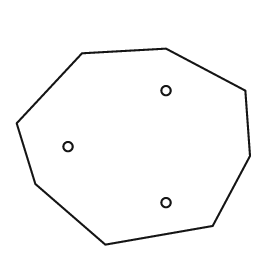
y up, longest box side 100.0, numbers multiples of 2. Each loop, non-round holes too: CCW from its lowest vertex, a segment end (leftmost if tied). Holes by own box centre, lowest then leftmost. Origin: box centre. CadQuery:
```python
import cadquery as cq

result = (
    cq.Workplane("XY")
    .moveTo(-12.0, -42.0)
    .lineTo(34.0, -34.0)
    .lineTo(50.0, -4.0)
    .lineTo(48.0, 24.0)
    .lineTo(14.0, 42.0)
    .lineTo(-22.0, 40.0)
    .lineTo(-50.0, 10.0)
    .lineTo(-42.0, -16.0)
    .close()
    .moveTo(14.0, -24.0)
    .circle(2.0)
    .moveTo(-28.0, 0.0)
    .circle(2.0)
    .moveTo(14.0, 24.0)
    .circle(2.0)
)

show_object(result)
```